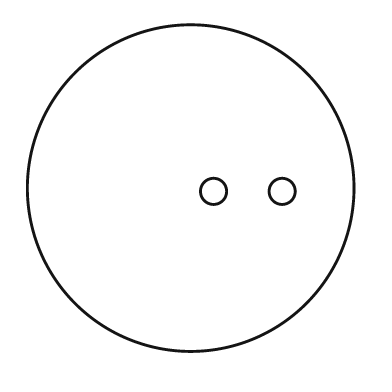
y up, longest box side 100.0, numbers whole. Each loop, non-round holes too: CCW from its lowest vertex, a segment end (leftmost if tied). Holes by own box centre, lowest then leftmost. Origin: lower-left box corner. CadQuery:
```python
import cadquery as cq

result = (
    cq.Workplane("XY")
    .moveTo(50.0, 50.0)
    .circle(50.0)
    .moveTo(57.0, 49.0)
    .circle(4.0)
    .moveTo(78.0, 49.0)
    .circle(4.0)
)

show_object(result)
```